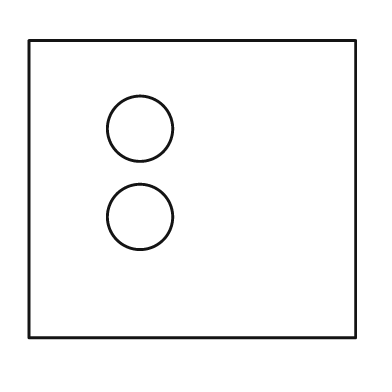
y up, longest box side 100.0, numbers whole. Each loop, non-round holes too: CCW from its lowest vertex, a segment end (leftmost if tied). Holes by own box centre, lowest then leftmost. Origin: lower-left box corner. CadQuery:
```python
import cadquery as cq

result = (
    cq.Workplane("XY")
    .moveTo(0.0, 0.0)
    .lineTo(100.0, 0.0)
    .lineTo(100.0, 91.0)
    .lineTo(0.0, 91.0)
    .close()
    .moveTo(34.0, 37.0)
    .circle(10.0)
    .moveTo(34.0, 64.0)
    .circle(10.0)
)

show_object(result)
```